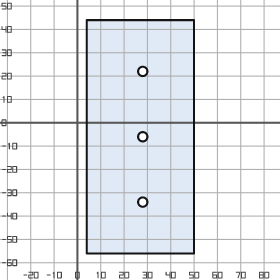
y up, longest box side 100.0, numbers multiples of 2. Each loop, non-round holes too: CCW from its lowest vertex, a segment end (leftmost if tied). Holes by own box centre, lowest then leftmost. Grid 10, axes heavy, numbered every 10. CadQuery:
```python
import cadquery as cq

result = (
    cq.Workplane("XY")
    .moveTo(4.0, -56.0)
    .lineTo(50.0, -56.0)
    .lineTo(50.0, 44.0)
    .lineTo(4.0, 44.0)
    .close()
    .moveTo(28.0, -34.0)
    .circle(2.0)
    .moveTo(28.0, -6.0)
    .circle(2.0)
    .moveTo(28.0, 22.0)
    .circle(2.0)
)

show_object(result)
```